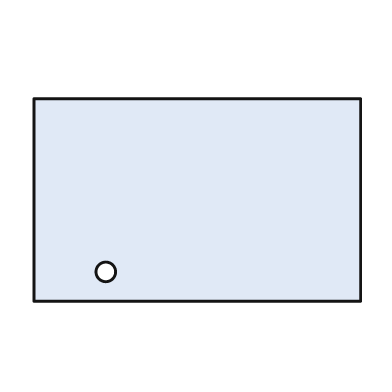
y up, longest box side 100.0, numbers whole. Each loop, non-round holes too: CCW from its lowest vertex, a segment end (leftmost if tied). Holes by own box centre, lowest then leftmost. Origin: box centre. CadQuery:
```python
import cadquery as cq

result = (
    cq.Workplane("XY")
    .moveTo(-50.0, -31.0)
    .lineTo(50.0, -31.0)
    .lineTo(50.0, 31.0)
    .lineTo(-50.0, 31.0)
    .close()
    .moveTo(-28.0, -22.0)
    .circle(3.0)
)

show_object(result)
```